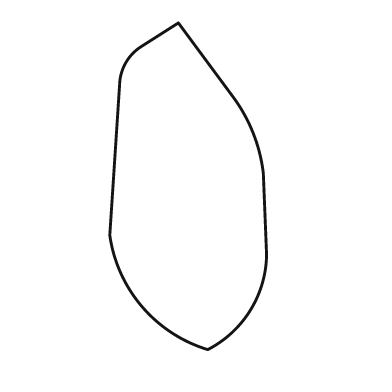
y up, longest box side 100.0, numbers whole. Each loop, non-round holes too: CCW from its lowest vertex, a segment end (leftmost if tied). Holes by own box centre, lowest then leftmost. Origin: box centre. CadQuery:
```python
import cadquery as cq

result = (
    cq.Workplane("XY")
    .moveTo(6.0, -50.0)
    .threePointArc((19.0, -38.0), (24.0, -21.0))
    .lineTo(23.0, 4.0)
    .threePointArc((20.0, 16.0), (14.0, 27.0))
    .lineTo(-3.0, 50.0)
    .lineTo(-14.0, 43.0)
    .threePointArc((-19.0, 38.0), (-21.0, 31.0))
    .lineTo(-24.0, -15.0)
    .threePointArc((-14.0, -37.0), (6.0, -50.0))
    .close()
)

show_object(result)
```